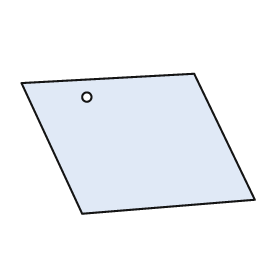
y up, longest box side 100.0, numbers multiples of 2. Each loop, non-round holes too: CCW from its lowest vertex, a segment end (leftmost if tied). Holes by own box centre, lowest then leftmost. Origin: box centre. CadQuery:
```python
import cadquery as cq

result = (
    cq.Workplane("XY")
    .moveTo(-24.0, -30.0)
    .lineTo(50.0, -24.0)
    .lineTo(24.0, 30.0)
    .lineTo(-50.0, 26.0)
    .close()
    .moveTo(-22.0, 20.0)
    .circle(2.0)
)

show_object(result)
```